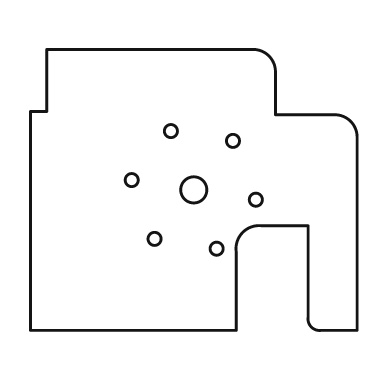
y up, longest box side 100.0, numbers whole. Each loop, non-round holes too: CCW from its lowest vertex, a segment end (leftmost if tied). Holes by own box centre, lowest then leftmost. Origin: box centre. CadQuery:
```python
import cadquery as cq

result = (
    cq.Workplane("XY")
    .moveTo(-50.0, -43.0)
    .lineTo(13.0, -43.0)
    .lineTo(13.0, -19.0)
    .threePointArc((15.0, -13.0), (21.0, -11.0))
    .lineTo(35.0, -11.0)
    .lineTo(35.0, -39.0)
    .threePointArc((36.0, -42.0), (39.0, -43.0))
    .lineTo(50.0, -43.0)
    .lineTo(50.0, 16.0)
    .threePointArc((48.0, 21.0), (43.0, 23.0))
    .lineTo(25.0, 23.0)
    .lineTo(25.0, 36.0)
    .threePointArc((23.0, 41.0), (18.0, 43.0))
    .lineTo(-45.0, 43.0)
    .lineTo(-45.0, 24.0)
    .lineTo(-50.0, 24.0)
    .close()
    .moveTo(7.0, -18.0)
    .circle(2.0)
    .moveTo(-12.0, -15.0)
    .circle(2.0)
    .moveTo(19.0, -3.0)
    .circle(2.0)
    .moveTo(0.0, 0.0)
    .circle(4.0)
    .moveTo(-19.0, 3.0)
    .circle(2.0)
    .moveTo(12.0, 15.0)
    .circle(2.0)
    .moveTo(-7.0, 18.0)
    .circle(2.0)
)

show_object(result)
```